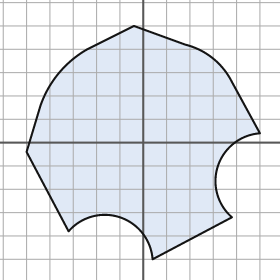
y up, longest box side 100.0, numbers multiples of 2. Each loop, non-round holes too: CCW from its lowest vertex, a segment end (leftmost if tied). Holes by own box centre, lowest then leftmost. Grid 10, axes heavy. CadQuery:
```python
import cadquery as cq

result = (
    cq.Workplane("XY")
    .moveTo(4.0, -50.0)
    .lineTo(38.0, -32.0)
    .threePointArc((32.0, -10.0), (50.0, 4.0))
    .lineTo(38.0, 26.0)
    .threePointArc((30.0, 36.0), (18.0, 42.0))
    .lineTo(-4.0, 50.0)
    .lineTo(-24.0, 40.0)
    .threePointArc((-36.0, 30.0), (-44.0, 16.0))
    .lineTo(-50.0, -4.0)
    .lineTo(-32.0, -38.0)
    .threePointArc((-10.0, -32.0), (4.0, -50.0))
    .close()
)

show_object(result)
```